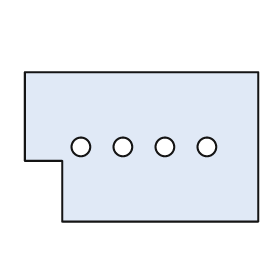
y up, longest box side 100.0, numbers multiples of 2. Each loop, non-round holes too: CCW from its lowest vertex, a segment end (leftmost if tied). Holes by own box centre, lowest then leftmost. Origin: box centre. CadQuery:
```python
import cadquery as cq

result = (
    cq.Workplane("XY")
    .moveTo(-34.0, -32.0)
    .lineTo(50.0, -32.0)
    .lineTo(50.0, 32.0)
    .lineTo(-50.0, 32.0)
    .lineTo(-50.0, -6.0)
    .lineTo(-34.0, -6.0)
    .close()
    .moveTo(-26.0, 0.0)
    .circle(4.0)
    .moveTo(-8.0, 0.0)
    .circle(4.0)
    .moveTo(10.0, 0.0)
    .circle(4.0)
    .moveTo(28.0, 0.0)
    .circle(4.0)
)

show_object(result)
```